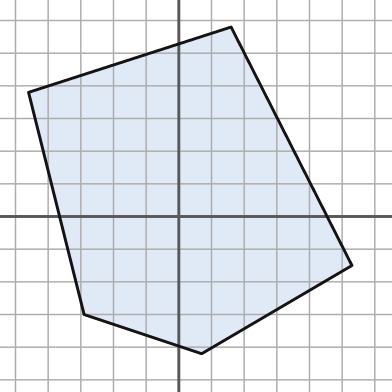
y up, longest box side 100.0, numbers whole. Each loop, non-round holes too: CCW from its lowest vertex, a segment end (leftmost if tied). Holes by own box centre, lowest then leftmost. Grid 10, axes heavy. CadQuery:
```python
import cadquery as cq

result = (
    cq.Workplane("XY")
    .moveTo(7.0, -42.0)
    .lineTo(53.0, -15.0)
    .lineTo(16.0, 58.0)
    .lineTo(-46.0, 38.0)
    .lineTo(-29.0, -30.0)
    .close()
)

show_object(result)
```